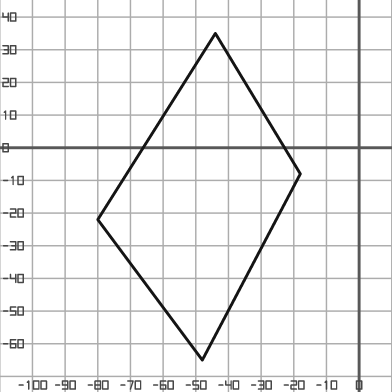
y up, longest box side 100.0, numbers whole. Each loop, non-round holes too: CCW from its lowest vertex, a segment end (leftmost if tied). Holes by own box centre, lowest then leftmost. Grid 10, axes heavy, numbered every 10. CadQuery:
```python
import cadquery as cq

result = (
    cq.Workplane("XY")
    .moveTo(-48.0, -65.0)
    .lineTo(-18.0, -8.0)
    .lineTo(-44.0, 35.0)
    .lineTo(-80.0, -22.0)
    .close()
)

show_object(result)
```